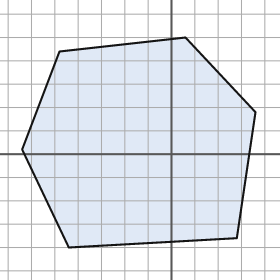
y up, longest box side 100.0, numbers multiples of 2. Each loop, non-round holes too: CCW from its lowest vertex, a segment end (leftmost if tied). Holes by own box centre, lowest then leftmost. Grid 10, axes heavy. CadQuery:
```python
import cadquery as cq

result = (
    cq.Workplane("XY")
    .moveTo(-44.0, -40.0)
    .lineTo(28.0, -36.0)
    .lineTo(36.0, 18.0)
    .lineTo(6.0, 50.0)
    .lineTo(-48.0, 44.0)
    .lineTo(-64.0, 2.0)
    .close()
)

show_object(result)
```